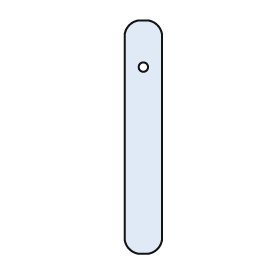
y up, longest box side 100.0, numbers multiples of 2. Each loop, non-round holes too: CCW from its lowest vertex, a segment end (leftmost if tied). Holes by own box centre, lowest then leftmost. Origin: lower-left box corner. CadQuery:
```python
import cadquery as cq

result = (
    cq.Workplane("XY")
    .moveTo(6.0, 0.0)
    .lineTo(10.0, 0.0)
    .threePointArc((14.0, 2.0), (16.0, 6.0))
    .lineTo(16.0, 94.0)
    .threePointArc((14.0, 98.0), (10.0, 100.0))
    .lineTo(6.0, 100.0)
    .threePointArc((2.0, 98.0), (0.0, 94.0))
    .lineTo(0.0, 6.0)
    .threePointArc((2.0, 2.0), (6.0, 0.0))
    .close()
    .moveTo(8.0, 80.0)
    .circle(2.0)
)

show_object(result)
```